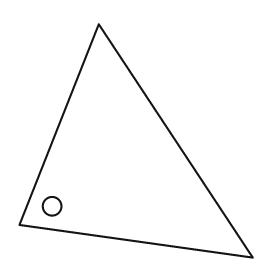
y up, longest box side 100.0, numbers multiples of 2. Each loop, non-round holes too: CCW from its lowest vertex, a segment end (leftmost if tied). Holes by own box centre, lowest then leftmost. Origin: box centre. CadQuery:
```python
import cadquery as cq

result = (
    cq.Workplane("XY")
    .moveTo(50.0, -50.0)
    .lineTo(-16.0, 50.0)
    .lineTo(-50.0, -36.0)
    .close()
    .moveTo(-36.0, -28.0)
    .circle(4.0)
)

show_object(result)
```